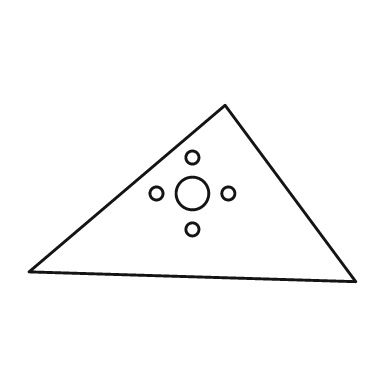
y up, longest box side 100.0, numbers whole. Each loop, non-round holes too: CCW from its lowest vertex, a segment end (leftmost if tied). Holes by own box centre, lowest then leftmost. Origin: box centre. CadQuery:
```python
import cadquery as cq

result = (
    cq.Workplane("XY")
    .moveTo(50.0, -27.0)
    .lineTo(10.0, 27.0)
    .lineTo(-50.0, -24.0)
    .close()
    .moveTo(0.0, -11.0)
    .circle(2.0)
    .moveTo(-11.0, 0.0)
    .circle(2.0)
    .moveTo(0.0, 0.0)
    .circle(5.0)
    .moveTo(11.0, 0.0)
    .circle(2.0)
    .moveTo(0.0, 11.0)
    .circle(2.0)
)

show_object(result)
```